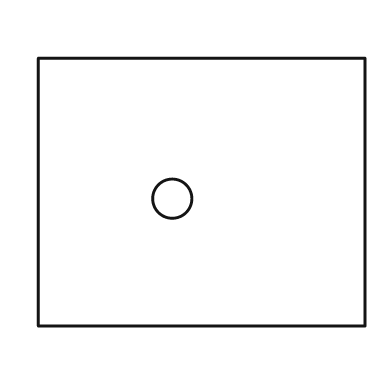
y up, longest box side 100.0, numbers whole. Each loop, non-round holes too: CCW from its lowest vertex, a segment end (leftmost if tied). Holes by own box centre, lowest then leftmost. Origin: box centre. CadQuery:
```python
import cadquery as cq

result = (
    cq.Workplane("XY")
    .moveTo(-50.0, -41.0)
    .lineTo(50.0, -41.0)
    .lineTo(50.0, 41.0)
    .lineTo(-50.0, 41.0)
    .close()
    .moveTo(-9.0, -2.0)
    .circle(6.0)
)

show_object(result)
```